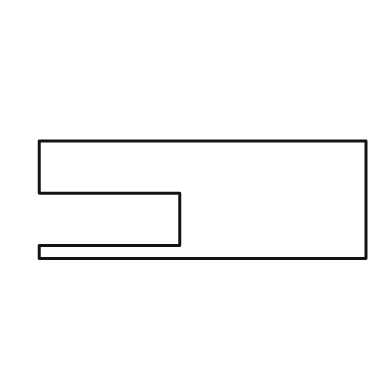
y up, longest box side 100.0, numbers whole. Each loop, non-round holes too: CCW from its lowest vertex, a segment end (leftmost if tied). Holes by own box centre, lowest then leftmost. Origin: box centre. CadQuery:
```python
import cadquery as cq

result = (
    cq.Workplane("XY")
    .moveTo(-50.0, -18.0)
    .lineTo(50.0, -18.0)
    .lineTo(50.0, 18.0)
    .lineTo(-50.0, 18.0)
    .lineTo(-50.0, 2.0)
    .lineTo(-7.0, 2.0)
    .lineTo(-7.0, -14.0)
    .lineTo(-50.0, -14.0)
    .close()
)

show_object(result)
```